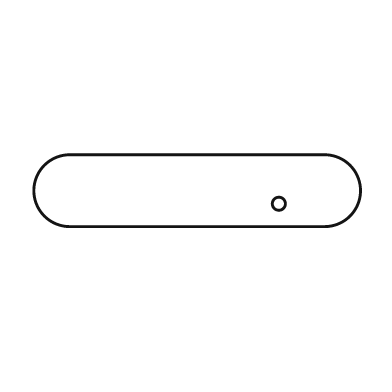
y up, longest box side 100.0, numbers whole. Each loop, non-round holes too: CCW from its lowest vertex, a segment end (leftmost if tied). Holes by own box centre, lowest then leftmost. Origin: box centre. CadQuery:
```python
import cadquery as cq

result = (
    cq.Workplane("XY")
    .moveTo(-39.0, -11.0)
    .lineTo(39.0, -11.0)
    .threePointArc((50.0, 0.0), (39.0, 11.0))
    .lineTo(-39.0, 11.0)
    .threePointArc((-50.0, 0.0), (-39.0, -11.0))
    .close()
    .moveTo(25.0, -4.0)
    .circle(2.0)
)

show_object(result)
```